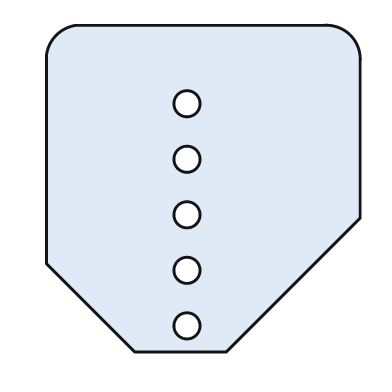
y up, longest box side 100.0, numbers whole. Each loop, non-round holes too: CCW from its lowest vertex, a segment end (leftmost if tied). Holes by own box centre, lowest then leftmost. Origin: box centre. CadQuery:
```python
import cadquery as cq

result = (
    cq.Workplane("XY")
    .moveTo(-21.0, -50.0)
    .lineTo(7.0, -50.0)
    .lineTo(48.0, -9.0)
    .lineTo(48.0, 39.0)
    .threePointArc((45.0, 47.0), (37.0, 50.0))
    .lineTo(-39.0, 50.0)
    .threePointArc((-45.0, 47.0), (-48.0, 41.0))
    .lineTo(-48.0, -23.0)
    .close()
    .moveTo(-5.0, -42.0)
    .circle(4.0)
    .moveTo(-5.0, -25.0)
    .circle(4.0)
    .moveTo(-5.0, -8.0)
    .circle(4.0)
    .moveTo(-5.0, 9.0)
    .circle(4.0)
    .moveTo(-5.0, 26.0)
    .circle(4.0)
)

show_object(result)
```